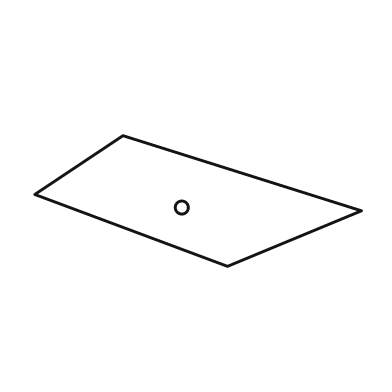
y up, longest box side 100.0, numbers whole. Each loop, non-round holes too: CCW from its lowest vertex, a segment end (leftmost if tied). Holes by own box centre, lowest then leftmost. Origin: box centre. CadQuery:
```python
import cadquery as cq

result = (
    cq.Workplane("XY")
    .moveTo(9.0, -20.0)
    .lineTo(50.0, -3.0)
    .lineTo(-23.0, 20.0)
    .lineTo(-50.0, 2.0)
    .close()
    .moveTo(-5.0, -2.0)
    .circle(2.0)
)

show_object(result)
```